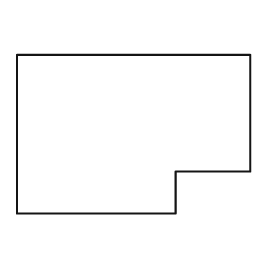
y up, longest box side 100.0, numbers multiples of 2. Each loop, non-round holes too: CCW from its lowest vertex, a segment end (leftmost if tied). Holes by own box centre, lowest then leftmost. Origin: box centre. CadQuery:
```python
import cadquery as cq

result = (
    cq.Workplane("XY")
    .moveTo(-50.0, -34.0)
    .lineTo(18.0, -34.0)
    .lineTo(18.0, -16.0)
    .lineTo(50.0, -16.0)
    .lineTo(50.0, 34.0)
    .lineTo(-50.0, 34.0)
    .close()
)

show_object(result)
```